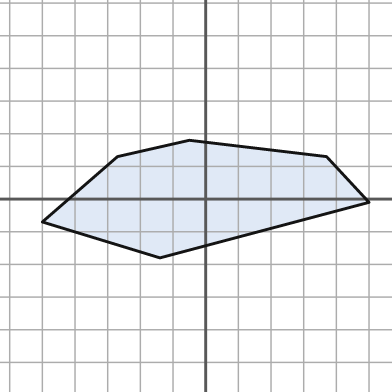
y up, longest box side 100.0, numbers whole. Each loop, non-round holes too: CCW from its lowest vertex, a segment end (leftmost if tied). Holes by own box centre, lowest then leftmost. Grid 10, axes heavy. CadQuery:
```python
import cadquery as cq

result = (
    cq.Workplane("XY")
    .moveTo(-14.0, -18.0)
    .lineTo(50.0, -1.0)
    .lineTo(37.0, 13.0)
    .lineTo(-5.0, 18.0)
    .lineTo(-27.0, 13.0)
    .lineTo(-50.0, -7.0)
    .close()
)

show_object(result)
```